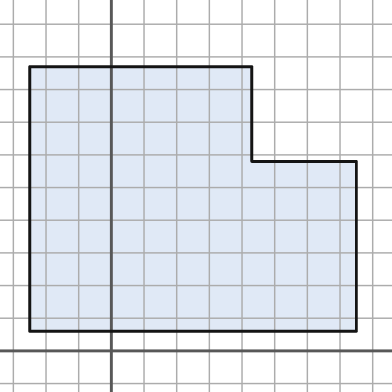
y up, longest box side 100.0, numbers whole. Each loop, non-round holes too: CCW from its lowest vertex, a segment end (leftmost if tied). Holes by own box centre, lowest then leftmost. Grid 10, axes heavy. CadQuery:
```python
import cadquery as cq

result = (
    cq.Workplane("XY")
    .moveTo(-25.0, 6.0)
    .lineTo(75.0, 6.0)
    .lineTo(75.0, 58.0)
    .lineTo(43.0, 58.0)
    .lineTo(43.0, 87.0)
    .lineTo(-25.0, 87.0)
    .close()
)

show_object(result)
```